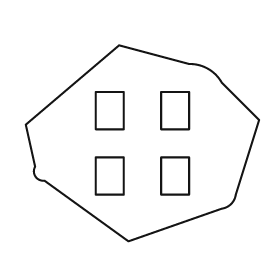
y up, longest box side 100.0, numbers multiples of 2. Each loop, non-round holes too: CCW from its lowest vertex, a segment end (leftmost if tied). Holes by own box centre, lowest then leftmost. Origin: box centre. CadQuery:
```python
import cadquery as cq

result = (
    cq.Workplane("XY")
    .moveTo(-6.0, -42.0)
    .lineTo(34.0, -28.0)
    .threePointArc((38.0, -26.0), (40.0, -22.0))
    .lineTo(50.0, 10.0)
    .lineTo(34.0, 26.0)
    .threePointArc((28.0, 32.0), (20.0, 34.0))
    .lineTo(-10.0, 42.0)
    .lineTo(-50.0, 8.0)
    .lineTo(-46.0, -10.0)
    .threePointArc((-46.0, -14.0), (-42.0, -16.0))
    .close()
    .moveTo(-20.0, -22.0)
    .lineTo(-8.0, -22.0)
    .lineTo(-8.0, -6.0)
    .lineTo(-20.0, -6.0)
    .close()
    .moveTo(8.0, -22.0)
    .lineTo(20.0, -22.0)
    .lineTo(20.0, -6.0)
    .lineTo(8.0, -6.0)
    .close()
    .moveTo(-20.0, 6.0)
    .lineTo(-8.0, 6.0)
    .lineTo(-8.0, 22.0)
    .lineTo(-20.0, 22.0)
    .close()
    .moveTo(8.0, 6.0)
    .lineTo(20.0, 6.0)
    .lineTo(20.0, 22.0)
    .lineTo(8.0, 22.0)
    .close()
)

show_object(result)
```